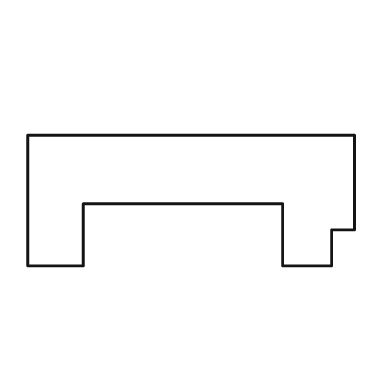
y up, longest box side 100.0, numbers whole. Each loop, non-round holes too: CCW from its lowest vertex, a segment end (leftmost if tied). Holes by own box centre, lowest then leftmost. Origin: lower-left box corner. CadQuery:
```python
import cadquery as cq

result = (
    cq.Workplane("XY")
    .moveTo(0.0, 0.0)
    .lineTo(17.0, 0.0)
    .lineTo(17.0, 19.0)
    .lineTo(78.0, 19.0)
    .lineTo(78.0, 0.0)
    .lineTo(93.0, 0.0)
    .lineTo(93.0, 11.0)
    .lineTo(100.0, 11.0)
    .lineTo(100.0, 40.0)
    .lineTo(0.0, 40.0)
    .close()
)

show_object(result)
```